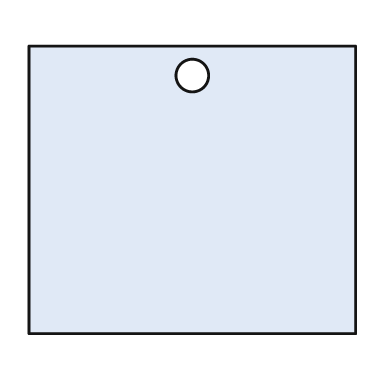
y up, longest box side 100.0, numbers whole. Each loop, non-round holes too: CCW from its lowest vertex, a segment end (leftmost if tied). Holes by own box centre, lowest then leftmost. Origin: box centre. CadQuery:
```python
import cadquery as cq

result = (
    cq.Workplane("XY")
    .moveTo(-50.0, -44.0)
    .lineTo(50.0, -44.0)
    .lineTo(50.0, 44.0)
    .lineTo(-50.0, 44.0)
    .close()
    .moveTo(0.0, 35.0)
    .circle(5.0)
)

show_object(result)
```